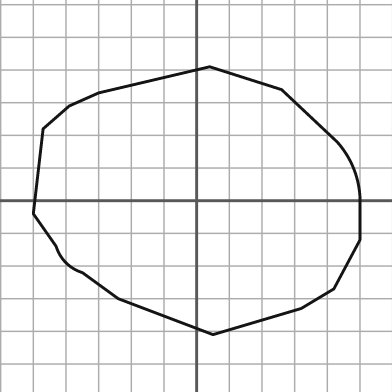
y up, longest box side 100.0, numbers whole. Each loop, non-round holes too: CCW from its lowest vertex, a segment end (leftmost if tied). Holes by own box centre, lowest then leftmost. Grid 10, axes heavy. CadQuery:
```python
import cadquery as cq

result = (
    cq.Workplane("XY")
    .moveTo(5.0, -41.0)
    .lineTo(32.0, -33.0)
    .lineTo(42.0, -27.0)
    .lineTo(50.0, -12.0)
    .lineTo(50.0, 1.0)
    .threePointArc((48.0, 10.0), (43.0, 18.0))
    .lineTo(26.0, 34.0)
    .lineTo(4.0, 41.0)
    .lineTo(-30.0, 33.0)
    .lineTo(-39.0, 29.0)
    .lineTo(-47.0, 22.0)
    .lineTo(-50.0, -4.0)
    .lineTo(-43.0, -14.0)
    .threePointArc((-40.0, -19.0), (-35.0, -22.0))
    .lineTo(-24.0, -30.0)
    .close()
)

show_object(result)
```